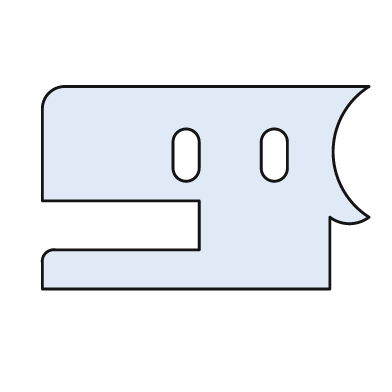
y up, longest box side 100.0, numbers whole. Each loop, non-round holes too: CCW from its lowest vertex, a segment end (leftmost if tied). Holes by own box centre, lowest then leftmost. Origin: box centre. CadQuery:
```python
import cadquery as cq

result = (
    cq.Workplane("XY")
    .moveTo(-50.0, -31.0)
    .lineTo(38.0, -31.0)
    .lineTo(38.0, -9.0)
    .threePointArc((44.0, -11.0), (50.0, -9.0))
    .threePointArc((39.0, 11.0), (50.0, 31.0))
    .lineTo(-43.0, 31.0)
    .threePointArc((-48.0, 29.0), (-50.0, 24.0))
    .lineTo(-50.0, -4.0)
    .lineTo(-2.0, -4.0)
    .lineTo(-2.0, -19.0)
    .lineTo(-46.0, -19.0)
    .threePointArc((-49.0, -20.0), (-50.0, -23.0))
    .close()
    .moveTo(-10.0, 6.0)
    .threePointArc((-6.0, 2.0), (-2.0, 6.0))
    .lineTo(-2.0, 14.0)
    .threePointArc((-6.0, 18.0), (-10.0, 14.0))
    .close()
    .moveTo(17.0, 6.0)
    .threePointArc((21.0, 2.0), (25.0, 6.0))
    .lineTo(25.0, 14.0)
    .threePointArc((21.0, 18.0), (17.0, 14.0))
    .close()
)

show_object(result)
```